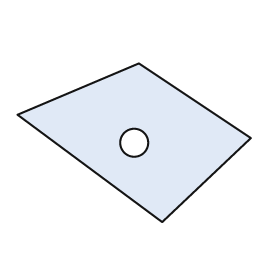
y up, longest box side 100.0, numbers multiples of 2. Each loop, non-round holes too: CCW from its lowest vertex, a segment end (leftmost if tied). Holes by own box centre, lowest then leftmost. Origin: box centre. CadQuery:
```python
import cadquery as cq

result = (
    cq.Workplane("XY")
    .moveTo(12.0, -34.0)
    .lineTo(50.0, 2.0)
    .lineTo(2.0, 34.0)
    .lineTo(-50.0, 12.0)
    .close()
    .moveTo(0.0, 0.0)
    .circle(6.0)
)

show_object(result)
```